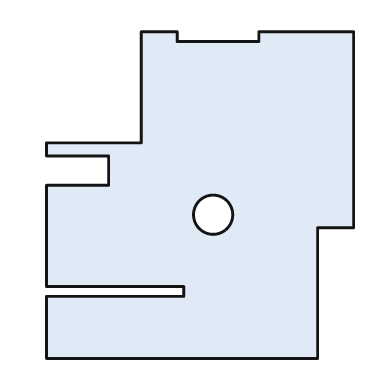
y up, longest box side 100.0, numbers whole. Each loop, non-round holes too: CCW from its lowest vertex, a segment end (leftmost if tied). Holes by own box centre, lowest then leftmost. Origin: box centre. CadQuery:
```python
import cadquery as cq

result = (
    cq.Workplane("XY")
    .moveTo(-47.0, -50.0)
    .lineTo(36.0, -50.0)
    .lineTo(36.0, -10.0)
    .lineTo(47.0, -10.0)
    .lineTo(47.0, 50.0)
    .lineTo(18.0, 50.0)
    .lineTo(18.0, 47.0)
    .lineTo(-7.0, 47.0)
    .lineTo(-7.0, 50.0)
    .lineTo(-18.0, 50.0)
    .lineTo(-18.0, 16.0)
    .lineTo(-47.0, 16.0)
    .lineTo(-47.0, 12.0)
    .lineTo(-28.0, 12.0)
    .lineTo(-28.0, 3.0)
    .lineTo(-47.0, 3.0)
    .lineTo(-47.0, -28.0)
    .lineTo(-5.0, -28.0)
    .lineTo(-5.0, -31.0)
    .lineTo(-47.0, -31.0)
    .close()
    .moveTo(4.0, -6.0)
    .circle(6.0)
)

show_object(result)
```